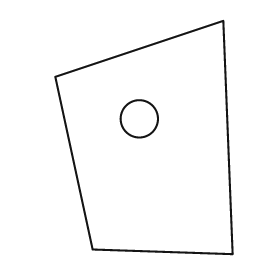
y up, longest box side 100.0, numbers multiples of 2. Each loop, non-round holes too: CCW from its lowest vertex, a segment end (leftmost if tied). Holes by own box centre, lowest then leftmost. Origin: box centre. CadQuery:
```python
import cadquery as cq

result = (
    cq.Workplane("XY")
    .moveTo(38.0, -50.0)
    .lineTo(34.0, 50.0)
    .lineTo(-38.0, 26.0)
    .lineTo(-22.0, -48.0)
    .close()
    .moveTo(-2.0, 8.0)
    .circle(8.0)
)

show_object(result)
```